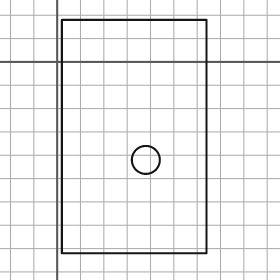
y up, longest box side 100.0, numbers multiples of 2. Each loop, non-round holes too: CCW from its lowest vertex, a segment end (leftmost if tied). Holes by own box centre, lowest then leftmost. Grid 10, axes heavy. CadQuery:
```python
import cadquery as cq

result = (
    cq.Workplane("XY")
    .moveTo(2.0, -82.0)
    .lineTo(64.0, -82.0)
    .lineTo(64.0, 18.0)
    .lineTo(2.0, 18.0)
    .close()
    .moveTo(38.0, -42.0)
    .circle(6.0)
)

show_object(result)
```